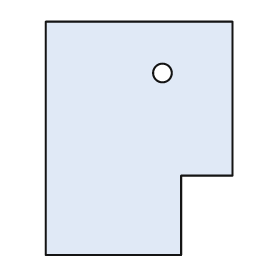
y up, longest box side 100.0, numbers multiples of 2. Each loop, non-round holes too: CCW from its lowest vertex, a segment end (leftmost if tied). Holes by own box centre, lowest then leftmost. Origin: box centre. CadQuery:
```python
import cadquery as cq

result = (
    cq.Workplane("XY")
    .moveTo(-40.0, -50.0)
    .lineTo(18.0, -50.0)
    .lineTo(18.0, -16.0)
    .lineTo(40.0, -16.0)
    .lineTo(40.0, 50.0)
    .lineTo(-40.0, 50.0)
    .close()
    .moveTo(10.0, 28.0)
    .circle(4.0)
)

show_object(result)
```